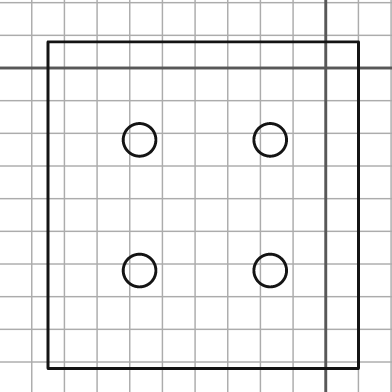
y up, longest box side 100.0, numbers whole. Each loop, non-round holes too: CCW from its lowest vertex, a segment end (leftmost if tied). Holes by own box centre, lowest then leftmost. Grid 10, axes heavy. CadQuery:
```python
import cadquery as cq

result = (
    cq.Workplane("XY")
    .moveTo(-85.0, -92.0)
    .lineTo(10.0, -92.0)
    .lineTo(10.0, 8.0)
    .lineTo(-85.0, 8.0)
    .close()
    .moveTo(-57.0, -62.0)
    .circle(5.0)
    .moveTo(-17.0, -62.0)
    .circle(5.0)
    .moveTo(-57.0, -22.0)
    .circle(5.0)
    .moveTo(-17.0, -22.0)
    .circle(5.0)
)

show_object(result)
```